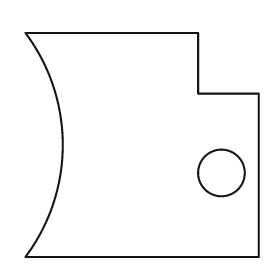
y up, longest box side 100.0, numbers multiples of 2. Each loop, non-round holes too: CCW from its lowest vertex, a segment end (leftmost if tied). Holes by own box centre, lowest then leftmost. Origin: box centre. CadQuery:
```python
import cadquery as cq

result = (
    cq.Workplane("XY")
    .moveTo(-50.0, -48.0)
    .lineTo(50.0, -48.0)
    .lineTo(50.0, 22.0)
    .lineTo(24.0, 22.0)
    .lineTo(24.0, 48.0)
    .lineTo(-50.0, 48.0)
    .threePointArc((-34.0, 0.0), (-50.0, -48.0))
    .close()
    .moveTo(34.0, -12.0)
    .circle(10.0)
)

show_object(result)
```